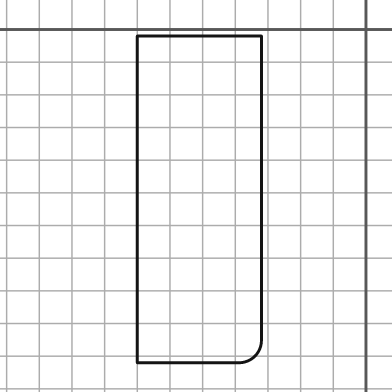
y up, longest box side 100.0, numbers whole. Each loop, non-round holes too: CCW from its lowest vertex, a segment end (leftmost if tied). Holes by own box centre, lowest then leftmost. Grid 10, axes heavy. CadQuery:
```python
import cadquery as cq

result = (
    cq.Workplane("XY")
    .moveTo(-70.0, -102.0)
    .lineTo(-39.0, -102.0)
    .threePointArc((-34.0, -100.0), (-32.0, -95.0))
    .lineTo(-32.0, -2.0)
    .lineTo(-70.0, -2.0)
    .close()
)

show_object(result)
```